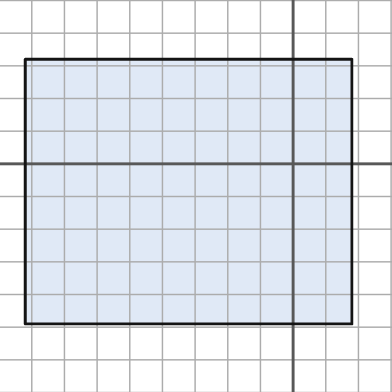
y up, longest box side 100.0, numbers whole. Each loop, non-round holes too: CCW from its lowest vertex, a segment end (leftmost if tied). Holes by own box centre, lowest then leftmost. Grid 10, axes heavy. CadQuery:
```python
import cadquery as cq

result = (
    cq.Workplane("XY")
    .moveTo(-82.0, -49.0)
    .lineTo(18.0, -49.0)
    .lineTo(18.0, 32.0)
    .lineTo(-82.0, 32.0)
    .close()
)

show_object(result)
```